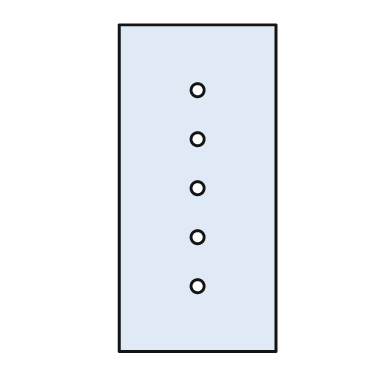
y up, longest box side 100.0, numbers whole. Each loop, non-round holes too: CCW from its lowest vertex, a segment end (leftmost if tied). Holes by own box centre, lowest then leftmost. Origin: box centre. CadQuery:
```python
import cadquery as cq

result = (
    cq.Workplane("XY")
    .moveTo(-24.0, -50.0)
    .lineTo(24.0, -50.0)
    .lineTo(24.0, 50.0)
    .lineTo(-24.0, 50.0)
    .close()
    .moveTo(0.0, -30.0)
    .circle(2.0)
    .moveTo(0.0, -15.0)
    .circle(2.0)
    .moveTo(0.0, 0.0)
    .circle(2.0)
    .moveTo(0.0, 15.0)
    .circle(2.0)
    .moveTo(0.0, 30.0)
    .circle(2.0)
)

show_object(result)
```